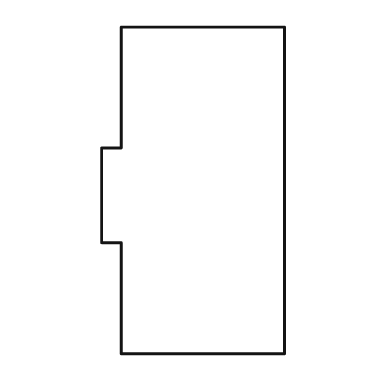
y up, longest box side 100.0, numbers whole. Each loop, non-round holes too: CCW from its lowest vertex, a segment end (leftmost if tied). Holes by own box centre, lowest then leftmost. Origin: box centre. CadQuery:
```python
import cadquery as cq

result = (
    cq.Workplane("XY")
    .moveTo(-22.0, -50.0)
    .lineTo(28.0, -50.0)
    .lineTo(28.0, 50.0)
    .lineTo(-22.0, 50.0)
    .lineTo(-22.0, 13.0)
    .lineTo(-28.0, 13.0)
    .lineTo(-28.0, -16.0)
    .lineTo(-22.0, -16.0)
    .close()
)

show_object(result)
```